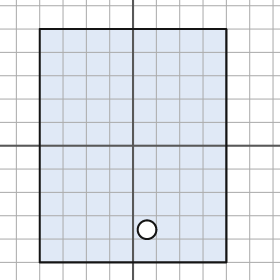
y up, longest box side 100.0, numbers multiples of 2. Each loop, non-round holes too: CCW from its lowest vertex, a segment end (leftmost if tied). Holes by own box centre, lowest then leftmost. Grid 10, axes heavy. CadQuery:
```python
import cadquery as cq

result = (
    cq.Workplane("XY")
    .moveTo(-40.0, -50.0)
    .lineTo(40.0, -50.0)
    .lineTo(40.0, 50.0)
    .lineTo(-40.0, 50.0)
    .close()
    .moveTo(6.0, -36.0)
    .circle(4.0)
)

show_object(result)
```